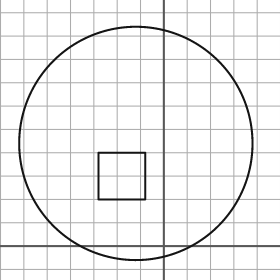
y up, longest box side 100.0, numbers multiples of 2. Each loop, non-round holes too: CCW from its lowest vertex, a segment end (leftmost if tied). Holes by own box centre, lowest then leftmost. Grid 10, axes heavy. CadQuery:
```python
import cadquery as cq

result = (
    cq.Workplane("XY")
    .moveTo(-12.0, 44.0)
    .circle(50.0)
    .moveTo(-28.0, 20.0)
    .lineTo(-8.0, 20.0)
    .lineTo(-8.0, 40.0)
    .lineTo(-28.0, 40.0)
    .close()
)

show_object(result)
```